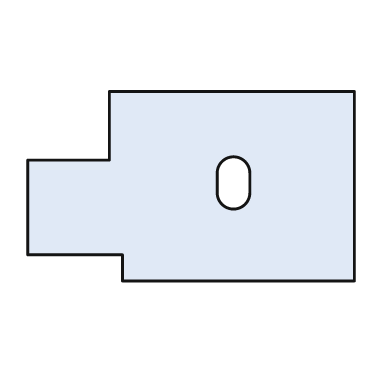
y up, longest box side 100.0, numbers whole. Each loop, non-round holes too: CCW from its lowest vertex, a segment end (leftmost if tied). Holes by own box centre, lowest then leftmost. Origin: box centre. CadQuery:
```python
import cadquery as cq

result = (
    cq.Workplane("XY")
    .moveTo(-21.0, -29.0)
    .lineTo(50.0, -29.0)
    .lineTo(50.0, 29.0)
    .lineTo(-25.0, 29.0)
    .lineTo(-25.0, 8.0)
    .lineTo(-50.0, 8.0)
    .lineTo(-50.0, -21.0)
    .lineTo(-21.0, -21.0)
    .close()
    .moveTo(8.0, -2.0)
    .threePointArc((13.0, -7.0), (18.0, -2.0))
    .lineTo(18.0, 4.0)
    .threePointArc((13.0, 9.0), (8.0, 4.0))
    .close()
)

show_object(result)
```